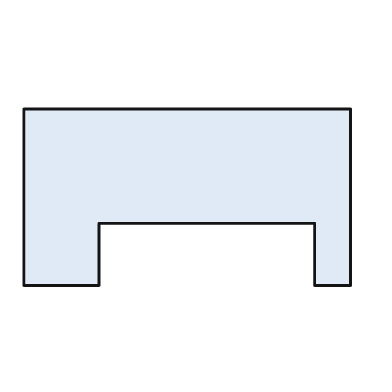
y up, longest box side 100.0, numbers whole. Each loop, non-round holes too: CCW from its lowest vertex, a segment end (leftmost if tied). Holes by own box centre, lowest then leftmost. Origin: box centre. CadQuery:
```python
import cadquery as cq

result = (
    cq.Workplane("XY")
    .moveTo(-50.0, -27.0)
    .lineTo(-27.0, -27.0)
    .lineTo(-27.0, -8.0)
    .lineTo(39.0, -8.0)
    .lineTo(39.0, -27.0)
    .lineTo(50.0, -27.0)
    .lineTo(50.0, 27.0)
    .lineTo(-50.0, 27.0)
    .close()
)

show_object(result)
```